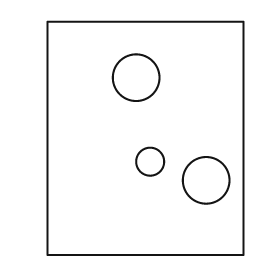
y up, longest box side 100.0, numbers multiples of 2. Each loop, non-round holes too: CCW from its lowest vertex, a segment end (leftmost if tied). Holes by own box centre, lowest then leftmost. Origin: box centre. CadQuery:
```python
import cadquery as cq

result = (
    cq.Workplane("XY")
    .moveTo(-42.0, -50.0)
    .lineTo(42.0, -50.0)
    .lineTo(42.0, 50.0)
    .lineTo(-42.0, 50.0)
    .close()
    .moveTo(26.0, -18.0)
    .circle(10.0)
    .moveTo(2.0, -10.0)
    .circle(6.0)
    .moveTo(-4.0, 26.0)
    .circle(10.0)
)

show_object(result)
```